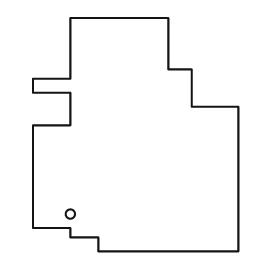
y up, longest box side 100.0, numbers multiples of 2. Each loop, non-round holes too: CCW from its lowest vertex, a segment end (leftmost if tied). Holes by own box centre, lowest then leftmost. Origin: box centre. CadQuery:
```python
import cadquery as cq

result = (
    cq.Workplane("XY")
    .moveTo(-16.0, -50.0)
    .lineTo(44.0, -50.0)
    .lineTo(44.0, 12.0)
    .lineTo(24.0, 12.0)
    .lineTo(24.0, 28.0)
    .lineTo(14.0, 28.0)
    .lineTo(14.0, 50.0)
    .lineTo(-28.0, 50.0)
    .lineTo(-28.0, 24.0)
    .lineTo(-44.0, 24.0)
    .lineTo(-44.0, 18.0)
    .lineTo(-28.0, 18.0)
    .lineTo(-28.0, 4.0)
    .lineTo(-44.0, 4.0)
    .lineTo(-44.0, -40.0)
    .lineTo(-28.0, -40.0)
    .lineTo(-28.0, -44.0)
    .lineTo(-16.0, -44.0)
    .close()
    .moveTo(-28.0, -34.0)
    .circle(2.0)
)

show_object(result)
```